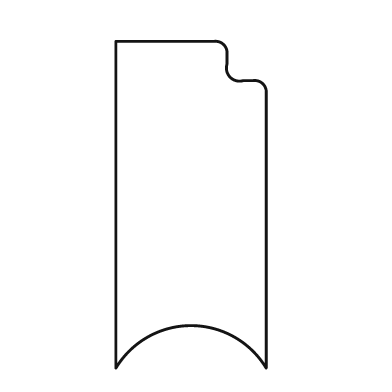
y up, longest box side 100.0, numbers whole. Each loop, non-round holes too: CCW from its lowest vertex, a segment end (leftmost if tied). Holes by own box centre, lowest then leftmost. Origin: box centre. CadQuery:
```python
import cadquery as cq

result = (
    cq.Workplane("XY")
    .moveTo(-23.0, -50.0)
    .threePointArc((0.0, -37.0), (23.0, -50.0))
    .lineTo(23.0, 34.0)
    .threePointArc((22.0, 37.0), (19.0, 38.0))
    .lineTo(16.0, 38.0)
    .threePointArc((12.0, 39.0), (11.0, 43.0))
    .lineTo(11.0, 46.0)
    .threePointArc((10.0, 49.0), (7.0, 50.0))
    .lineTo(-23.0, 50.0)
    .close()
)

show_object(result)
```